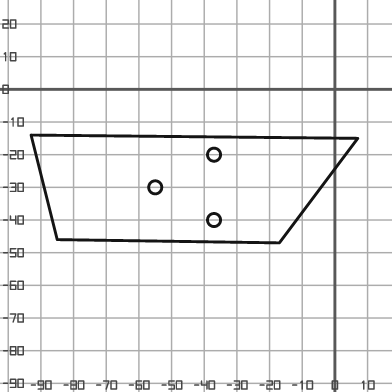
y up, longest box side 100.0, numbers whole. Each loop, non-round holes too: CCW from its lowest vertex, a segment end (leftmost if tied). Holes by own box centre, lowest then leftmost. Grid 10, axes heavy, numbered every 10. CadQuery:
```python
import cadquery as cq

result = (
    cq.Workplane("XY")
    .moveTo(-17.0, -47.0)
    .lineTo(7.0, -15.0)
    .lineTo(-93.0, -14.0)
    .lineTo(-85.0, -46.0)
    .close()
    .moveTo(-37.0, -40.0)
    .circle(2.0)
    .moveTo(-55.0, -30.0)
    .circle(2.0)
    .moveTo(-37.0, -20.0)
    .circle(2.0)
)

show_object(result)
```